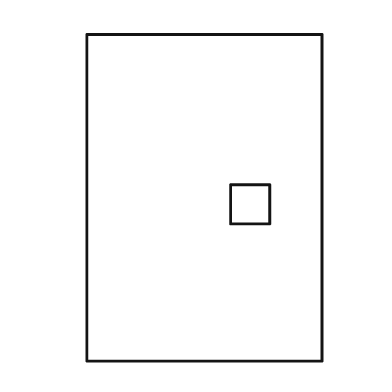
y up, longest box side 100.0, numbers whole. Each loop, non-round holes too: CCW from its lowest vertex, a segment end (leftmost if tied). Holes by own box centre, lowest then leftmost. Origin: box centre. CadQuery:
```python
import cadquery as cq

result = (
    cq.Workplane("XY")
    .moveTo(-36.0, -50.0)
    .lineTo(36.0, -50.0)
    .lineTo(36.0, 50.0)
    .lineTo(-36.0, 50.0)
    .close()
    .moveTo(8.0, -8.0)
    .lineTo(20.0, -8.0)
    .lineTo(20.0, 4.0)
    .lineTo(8.0, 4.0)
    .close()
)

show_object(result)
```